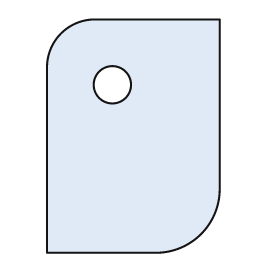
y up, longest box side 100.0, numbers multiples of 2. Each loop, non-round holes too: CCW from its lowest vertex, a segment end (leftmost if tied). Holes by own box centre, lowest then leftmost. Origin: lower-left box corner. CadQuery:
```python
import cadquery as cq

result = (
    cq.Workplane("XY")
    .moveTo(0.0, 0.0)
    .lineTo(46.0, 0.0)
    .threePointArc((66.0, 8.0), (74.0, 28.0))
    .lineTo(74.0, 100.0)
    .lineTo(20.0, 100.0)
    .threePointArc((6.0, 94.0), (0.0, 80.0))
    .close()
    .moveTo(28.0, 72.0)
    .circle(8.0)
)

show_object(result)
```